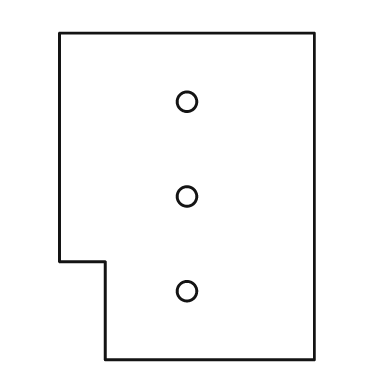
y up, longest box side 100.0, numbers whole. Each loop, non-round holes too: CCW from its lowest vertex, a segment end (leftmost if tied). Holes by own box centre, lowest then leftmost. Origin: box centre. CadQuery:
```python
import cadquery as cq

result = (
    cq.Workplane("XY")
    .moveTo(-25.0, -50.0)
    .lineTo(39.0, -50.0)
    .lineTo(39.0, 50.0)
    .lineTo(-39.0, 50.0)
    .lineTo(-39.0, -20.0)
    .lineTo(-25.0, -20.0)
    .close()
    .moveTo(0.0, -29.0)
    .circle(3.0)
    .moveTo(0.0, 0.0)
    .circle(3.0)
    .moveTo(0.0, 29.0)
    .circle(3.0)
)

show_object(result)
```